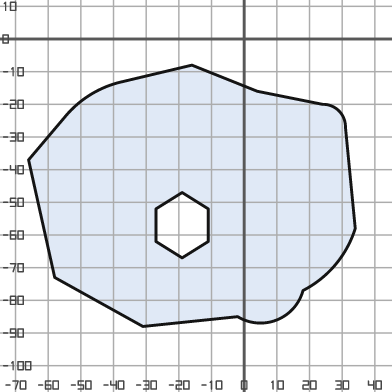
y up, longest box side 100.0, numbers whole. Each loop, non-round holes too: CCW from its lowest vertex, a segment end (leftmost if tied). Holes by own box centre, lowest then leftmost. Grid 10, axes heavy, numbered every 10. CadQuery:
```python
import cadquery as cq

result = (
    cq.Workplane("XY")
    .moveTo(-31.0, -88.0)
    .lineTo(-2.0, -85.0)
    .threePointArc((10.0, -86.0), (18.0, -77.0))
    .threePointArc((28.0, -69.0), (34.0, -58.0))
    .lineTo(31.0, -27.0)
    .threePointArc((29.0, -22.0), (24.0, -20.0))
    .lineTo(4.0, -16.0)
    .lineTo(-16.0, -8.0)
    .lineTo(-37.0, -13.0)
    .threePointArc((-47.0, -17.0), (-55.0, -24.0))
    .lineTo(-66.0, -37.0)
    .lineTo(-58.0, -73.0)
    .close()
    .moveTo(-19.0, -67.0)
    .lineTo(-11.0, -62.0)
    .lineTo(-11.0, -52.0)
    .lineTo(-19.0, -47.0)
    .lineTo(-27.0, -52.0)
    .lineTo(-27.0, -62.0)
    .close()
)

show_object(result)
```